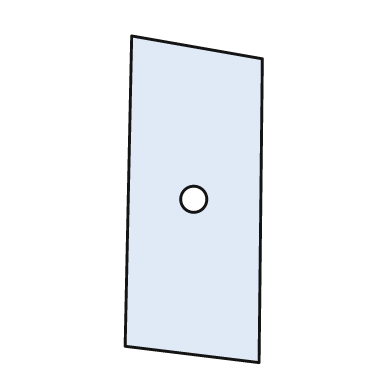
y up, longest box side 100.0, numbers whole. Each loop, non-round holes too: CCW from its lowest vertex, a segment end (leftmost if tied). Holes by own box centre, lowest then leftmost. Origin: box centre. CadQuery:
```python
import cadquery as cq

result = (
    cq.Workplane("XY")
    .moveTo(20.0, -50.0)
    .lineTo(21.0, 43.0)
    .lineTo(-19.0, 50.0)
    .lineTo(-21.0, -45.0)
    .close()
    .moveTo(0.0, 0.0)
    .circle(4.0)
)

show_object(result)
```